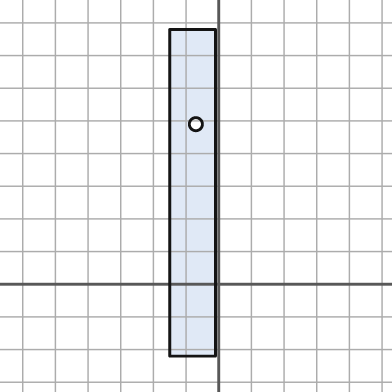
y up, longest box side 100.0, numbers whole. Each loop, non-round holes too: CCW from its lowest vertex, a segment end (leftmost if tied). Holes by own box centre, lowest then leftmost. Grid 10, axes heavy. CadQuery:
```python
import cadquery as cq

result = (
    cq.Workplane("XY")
    .moveTo(-15.0, -22.0)
    .lineTo(-1.0, -22.0)
    .lineTo(-1.0, 78.0)
    .lineTo(-15.0, 78.0)
    .close()
    .moveTo(-7.0, 49.0)
    .circle(2.0)
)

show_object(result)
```